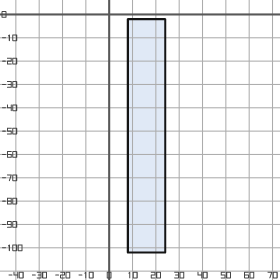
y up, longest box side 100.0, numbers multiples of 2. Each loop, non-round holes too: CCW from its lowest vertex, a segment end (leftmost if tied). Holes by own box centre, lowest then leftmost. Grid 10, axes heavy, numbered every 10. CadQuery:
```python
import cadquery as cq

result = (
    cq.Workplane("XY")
    .moveTo(8.0, -102.0)
    .lineTo(24.0, -102.0)
    .lineTo(24.0, -2.0)
    .lineTo(8.0, -2.0)
    .close()
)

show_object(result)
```